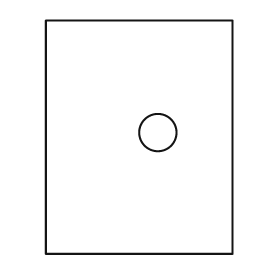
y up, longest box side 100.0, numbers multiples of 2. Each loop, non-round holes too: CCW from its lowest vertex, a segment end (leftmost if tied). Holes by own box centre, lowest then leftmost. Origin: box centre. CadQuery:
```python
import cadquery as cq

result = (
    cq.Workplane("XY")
    .moveTo(-40.0, -50.0)
    .lineTo(40.0, -50.0)
    .lineTo(40.0, 50.0)
    .lineTo(-40.0, 50.0)
    .close()
    .moveTo(8.0, 2.0)
    .circle(8.0)
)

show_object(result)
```